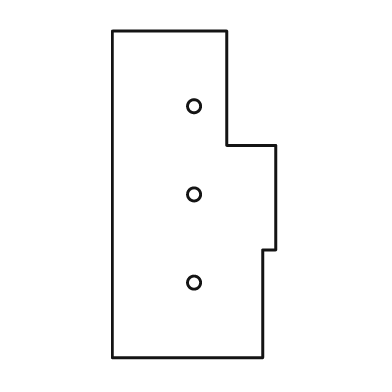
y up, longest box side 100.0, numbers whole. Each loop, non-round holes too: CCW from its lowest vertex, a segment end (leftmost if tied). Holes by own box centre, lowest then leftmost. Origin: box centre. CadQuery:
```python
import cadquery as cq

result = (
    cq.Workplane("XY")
    .moveTo(-25.0, -50.0)
    .lineTo(21.0, -50.0)
    .lineTo(21.0, -17.0)
    .lineTo(25.0, -17.0)
    .lineTo(25.0, 15.0)
    .lineTo(10.0, 15.0)
    .lineTo(10.0, 50.0)
    .lineTo(-25.0, 50.0)
    .close()
    .moveTo(0.0, -27.0)
    .circle(2.0)
    .moveTo(0.0, 0.0)
    .circle(2.0)
    .moveTo(0.0, 27.0)
    .circle(2.0)
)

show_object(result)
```